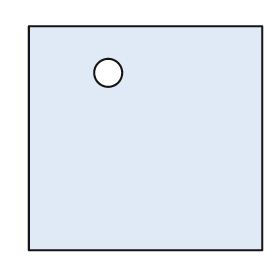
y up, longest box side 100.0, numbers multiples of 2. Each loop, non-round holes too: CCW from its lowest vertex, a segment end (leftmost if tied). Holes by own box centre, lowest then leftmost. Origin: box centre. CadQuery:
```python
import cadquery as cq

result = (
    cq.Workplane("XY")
    .moveTo(-50.0, -48.0)
    .lineTo(50.0, -48.0)
    .lineTo(50.0, 48.0)
    .lineTo(-50.0, 48.0)
    .close()
    .moveTo(-16.0, 28.0)
    .circle(6.0)
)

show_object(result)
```